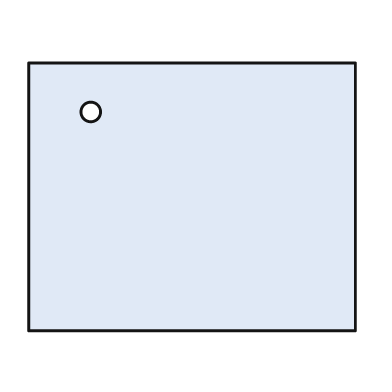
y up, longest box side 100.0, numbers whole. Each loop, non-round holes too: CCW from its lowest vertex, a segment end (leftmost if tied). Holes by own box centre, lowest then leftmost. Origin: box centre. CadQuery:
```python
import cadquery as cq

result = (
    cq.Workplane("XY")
    .moveTo(-50.0, -41.0)
    .lineTo(50.0, -41.0)
    .lineTo(50.0, 41.0)
    .lineTo(-50.0, 41.0)
    .close()
    .moveTo(-31.0, 26.0)
    .circle(3.0)
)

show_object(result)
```